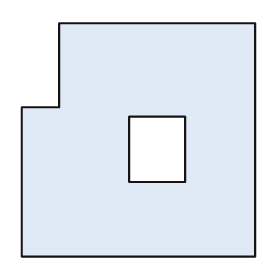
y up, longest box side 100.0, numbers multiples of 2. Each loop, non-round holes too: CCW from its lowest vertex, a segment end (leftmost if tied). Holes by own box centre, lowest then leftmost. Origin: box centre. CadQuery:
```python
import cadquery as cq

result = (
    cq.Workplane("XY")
    .moveTo(-50.0, -50.0)
    .lineTo(50.0, -50.0)
    .lineTo(50.0, 50.0)
    .lineTo(-34.0, 50.0)
    .lineTo(-34.0, 14.0)
    .lineTo(-50.0, 14.0)
    .close()
    .moveTo(-4.0, -18.0)
    .lineTo(20.0, -18.0)
    .lineTo(20.0, 10.0)
    .lineTo(-4.0, 10.0)
    .close()
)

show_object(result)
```